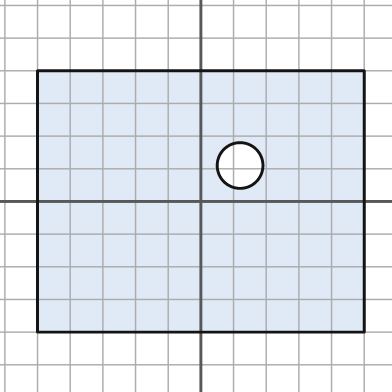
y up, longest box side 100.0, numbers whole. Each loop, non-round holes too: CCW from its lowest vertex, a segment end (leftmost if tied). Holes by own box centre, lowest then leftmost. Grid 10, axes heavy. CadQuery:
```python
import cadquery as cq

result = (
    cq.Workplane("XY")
    .moveTo(-50.0, -40.0)
    .lineTo(50.0, -40.0)
    .lineTo(50.0, 40.0)
    .lineTo(-50.0, 40.0)
    .close()
    .moveTo(12.0, 11.0)
    .circle(7.0)
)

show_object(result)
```